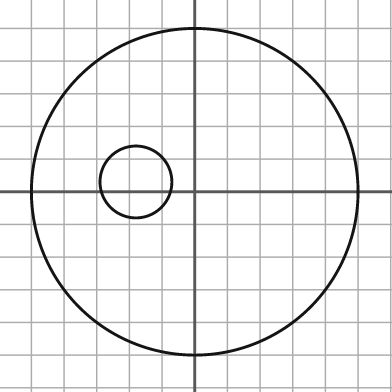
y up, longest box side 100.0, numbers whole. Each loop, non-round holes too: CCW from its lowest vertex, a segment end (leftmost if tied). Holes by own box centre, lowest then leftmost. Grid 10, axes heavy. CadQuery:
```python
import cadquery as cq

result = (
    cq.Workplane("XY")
    .moveTo(0.0, 0.0)
    .circle(50.0)
    .moveTo(-18.0, 3.0)
    .circle(11.0)
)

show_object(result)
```